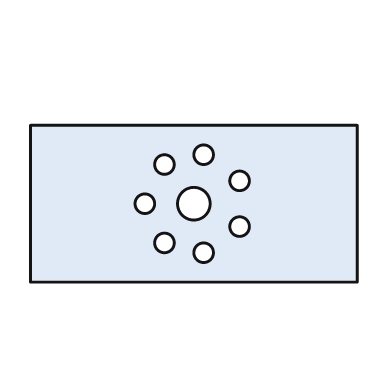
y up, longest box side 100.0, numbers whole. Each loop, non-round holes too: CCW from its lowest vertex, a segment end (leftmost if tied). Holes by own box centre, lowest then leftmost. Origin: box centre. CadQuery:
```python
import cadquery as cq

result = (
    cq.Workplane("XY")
    .moveTo(-50.0, -24.0)
    .lineTo(50.0, -24.0)
    .lineTo(50.0, 24.0)
    .lineTo(-50.0, 24.0)
    .close()
    .moveTo(3.0, -15.0)
    .circle(3.0)
    .moveTo(-9.0, -12.0)
    .circle(3.0)
    .moveTo(14.0, -7.0)
    .circle(3.0)
    .moveTo(-15.0, 0.0)
    .circle(3.0)
    .moveTo(0.0, 0.0)
    .circle(5.0)
    .moveTo(14.0, 7.0)
    .circle(3.0)
    .moveTo(-9.0, 12.0)
    .circle(3.0)
    .moveTo(3.0, 15.0)
    .circle(3.0)
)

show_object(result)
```